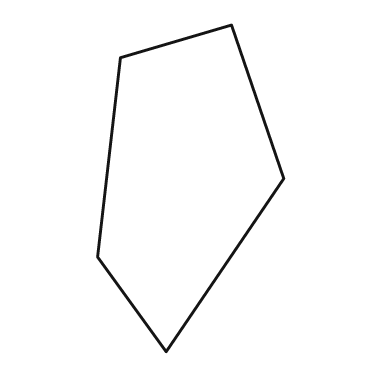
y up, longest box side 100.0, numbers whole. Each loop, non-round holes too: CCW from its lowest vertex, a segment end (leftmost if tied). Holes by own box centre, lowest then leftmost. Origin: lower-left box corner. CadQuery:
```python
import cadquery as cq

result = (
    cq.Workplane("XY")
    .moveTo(21.0, 0.0)
    .lineTo(57.0, 53.0)
    .lineTo(41.0, 100.0)
    .lineTo(7.0, 90.0)
    .lineTo(0.0, 29.0)
    .close()
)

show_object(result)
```